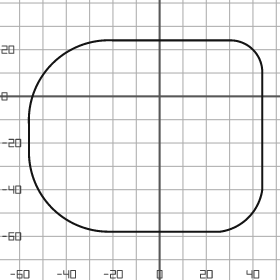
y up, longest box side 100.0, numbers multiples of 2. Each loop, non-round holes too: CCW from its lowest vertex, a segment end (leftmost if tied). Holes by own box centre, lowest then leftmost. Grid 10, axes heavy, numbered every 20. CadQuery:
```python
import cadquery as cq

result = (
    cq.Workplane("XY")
    .moveTo(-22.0, -58.0)
    .lineTo(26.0, -58.0)
    .threePointArc((38.0, -52.0), (44.0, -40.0))
    .lineTo(44.0, 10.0)
    .threePointArc((40.0, 20.0), (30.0, 24.0))
    .lineTo(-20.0, 24.0)
    .threePointArc((-46.0, 14.0), (-56.0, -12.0))
    .lineTo(-56.0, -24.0)
    .threePointArc((-46.0, -48.0), (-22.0, -58.0))
    .close()
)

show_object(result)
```